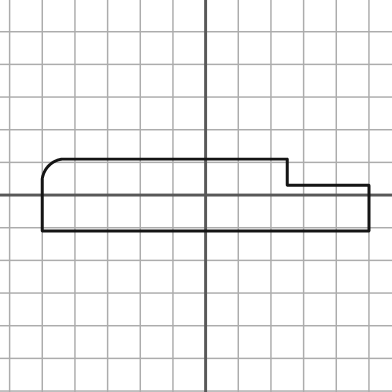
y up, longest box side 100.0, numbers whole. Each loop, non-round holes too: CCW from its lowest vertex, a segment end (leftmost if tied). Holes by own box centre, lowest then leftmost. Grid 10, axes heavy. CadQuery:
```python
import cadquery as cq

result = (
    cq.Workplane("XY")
    .moveTo(-50.0, -11.0)
    .lineTo(50.0, -11.0)
    .lineTo(50.0, 3.0)
    .lineTo(25.0, 3.0)
    .lineTo(25.0, 11.0)
    .lineTo(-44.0, 11.0)
    .threePointArc((-48.0, 9.0), (-50.0, 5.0))
    .close()
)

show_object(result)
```